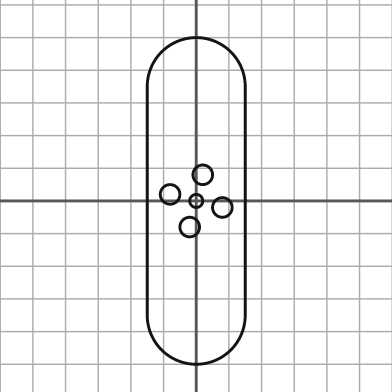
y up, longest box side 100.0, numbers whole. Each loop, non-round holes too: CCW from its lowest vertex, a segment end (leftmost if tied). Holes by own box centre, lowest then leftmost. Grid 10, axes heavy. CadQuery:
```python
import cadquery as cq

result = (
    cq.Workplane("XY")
    .moveTo(-15.0, -35.0)
    .threePointArc((0.0, -50.0), (15.0, -35.0))
    .lineTo(15.0, 35.0)
    .threePointArc((0.0, 50.0), (-15.0, 35.0))
    .close()
    .moveTo(-2.0, -8.0)
    .circle(3.0)
    .moveTo(8.0, -2.0)
    .circle(3.0)
    .moveTo(0.0, 0.0)
    .circle(2.0)
    .moveTo(-8.0, 2.0)
    .circle(3.0)
    .moveTo(2.0, 8.0)
    .circle(3.0)
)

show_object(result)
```